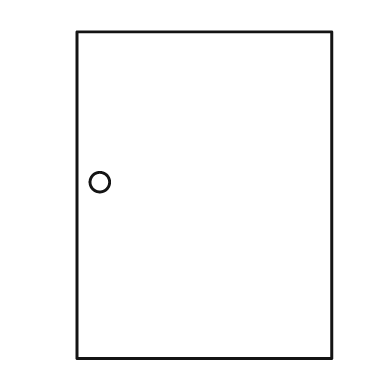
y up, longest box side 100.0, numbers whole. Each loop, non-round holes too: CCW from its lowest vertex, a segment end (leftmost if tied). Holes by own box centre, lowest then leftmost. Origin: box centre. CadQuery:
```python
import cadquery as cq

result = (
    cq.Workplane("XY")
    .moveTo(-39.0, -50.0)
    .lineTo(39.0, -50.0)
    .lineTo(39.0, 50.0)
    .lineTo(-39.0, 50.0)
    .close()
    .moveTo(-32.0, 4.0)
    .circle(3.0)
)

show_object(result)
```